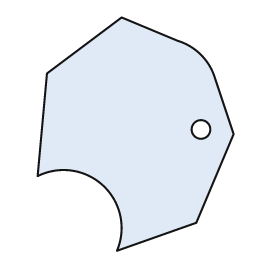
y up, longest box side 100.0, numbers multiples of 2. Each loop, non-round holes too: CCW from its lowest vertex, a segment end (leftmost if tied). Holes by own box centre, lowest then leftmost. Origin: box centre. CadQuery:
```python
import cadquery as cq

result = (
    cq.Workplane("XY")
    .moveTo(-8.0, -50.0)
    .lineTo(26.0, -38.0)
    .lineTo(42.0, 0.0)
    .lineTo(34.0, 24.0)
    .threePointArc((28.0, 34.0), (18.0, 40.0))
    .lineTo(-6.0, 50.0)
    .lineTo(-38.0, 26.0)
    .lineTo(-42.0, -18.0)
    .threePointArc((-14.0, -22.0), (-8.0, -50.0))
    .close()
    .moveTo(28.0, 2.0)
    .circle(4.0)
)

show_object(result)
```